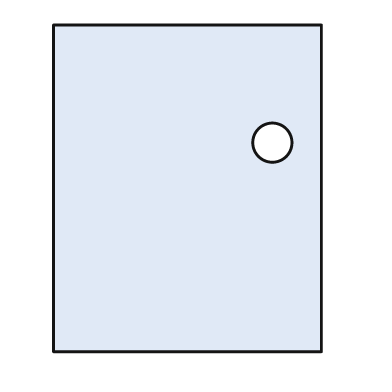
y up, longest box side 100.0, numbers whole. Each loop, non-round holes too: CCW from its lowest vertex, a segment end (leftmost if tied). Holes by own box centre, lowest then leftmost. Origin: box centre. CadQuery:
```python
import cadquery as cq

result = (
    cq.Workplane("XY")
    .moveTo(-41.0, -50.0)
    .lineTo(41.0, -50.0)
    .lineTo(41.0, 50.0)
    .lineTo(-41.0, 50.0)
    .close()
    .moveTo(26.0, 14.0)
    .circle(6.0)
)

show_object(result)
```